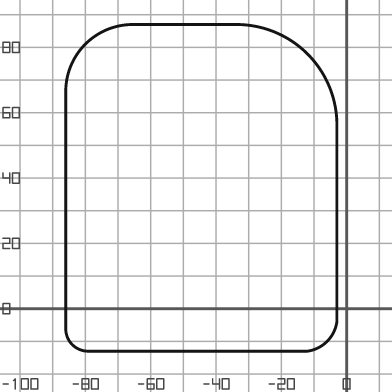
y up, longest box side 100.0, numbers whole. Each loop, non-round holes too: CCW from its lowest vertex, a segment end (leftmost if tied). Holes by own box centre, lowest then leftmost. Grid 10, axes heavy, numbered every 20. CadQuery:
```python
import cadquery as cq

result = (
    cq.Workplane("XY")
    .moveTo(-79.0, -13.0)
    .lineTo(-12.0, -13.0)
    .threePointArc((-6.0, -10.0), (-3.0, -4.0))
    .lineTo(-3.0, 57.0)
    .threePointArc((-12.0, 78.0), (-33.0, 87.0))
    .lineTo(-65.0, 87.0)
    .threePointArc((-80.0, 81.0), (-86.0, 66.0))
    .lineTo(-86.0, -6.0)
    .threePointArc((-84.0, -11.0), (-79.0, -13.0))
    .close()
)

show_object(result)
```